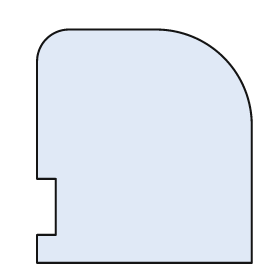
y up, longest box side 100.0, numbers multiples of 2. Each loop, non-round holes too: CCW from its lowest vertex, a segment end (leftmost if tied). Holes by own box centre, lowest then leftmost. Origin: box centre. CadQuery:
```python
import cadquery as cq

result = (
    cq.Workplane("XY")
    .moveTo(-46.0, -50.0)
    .lineTo(46.0, -50.0)
    .lineTo(46.0, 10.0)
    .threePointArc((34.0, 38.0), (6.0, 50.0))
    .lineTo(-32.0, 50.0)
    .threePointArc((-42.0, 46.0), (-46.0, 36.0))
    .lineTo(-46.0, -14.0)
    .lineTo(-38.0, -14.0)
    .lineTo(-38.0, -38.0)
    .lineTo(-46.0, -38.0)
    .close()
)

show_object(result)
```